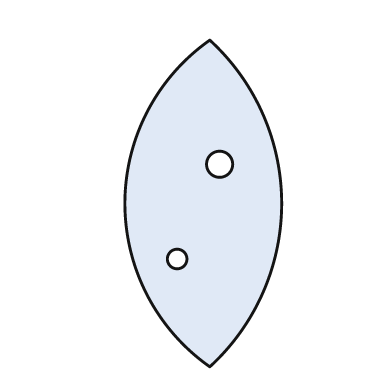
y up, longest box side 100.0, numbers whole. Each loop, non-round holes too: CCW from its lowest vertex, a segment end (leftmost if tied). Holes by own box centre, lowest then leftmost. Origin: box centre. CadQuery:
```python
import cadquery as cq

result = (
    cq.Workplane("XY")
    .moveTo(2.0, -50.0)
    .threePointArc((24.0, 0.0), (2.0, 50.0))
    .threePointArc((-24.0, 0.0), (2.0, -50.0))
    .close()
    .moveTo(-8.0, -17.0)
    .circle(3.0)
    .moveTo(5.0, 12.0)
    .circle(4.0)
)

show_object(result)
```